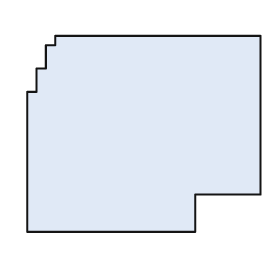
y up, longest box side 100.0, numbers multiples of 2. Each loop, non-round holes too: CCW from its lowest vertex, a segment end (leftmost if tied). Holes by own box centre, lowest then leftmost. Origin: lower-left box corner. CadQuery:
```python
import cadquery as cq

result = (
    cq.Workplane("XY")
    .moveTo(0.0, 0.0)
    .lineTo(72.0, 0.0)
    .lineTo(72.0, 16.0)
    .lineTo(100.0, 16.0)
    .lineTo(100.0, 84.0)
    .lineTo(12.0, 84.0)
    .lineTo(12.0, 80.0)
    .lineTo(8.0, 80.0)
    .lineTo(8.0, 70.0)
    .lineTo(4.0, 70.0)
    .lineTo(4.0, 60.0)
    .lineTo(0.0, 60.0)
    .close()
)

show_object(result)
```